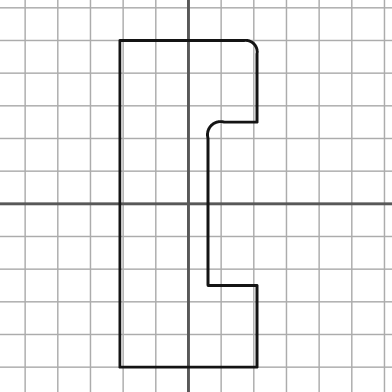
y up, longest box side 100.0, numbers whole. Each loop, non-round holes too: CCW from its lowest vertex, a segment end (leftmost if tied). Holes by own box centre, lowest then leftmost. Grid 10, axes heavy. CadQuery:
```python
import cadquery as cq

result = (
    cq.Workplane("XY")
    .moveTo(-21.0, -50.0)
    .lineTo(21.0, -50.0)
    .lineTo(21.0, -25.0)
    .lineTo(6.0, -25.0)
    .lineTo(6.0, 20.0)
    .threePointArc((7.0, 24.0), (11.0, 25.0))
    .lineTo(21.0, 25.0)
    .lineTo(21.0, 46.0)
    .threePointArc((20.0, 49.0), (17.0, 50.0))
    .lineTo(-21.0, 50.0)
    .close()
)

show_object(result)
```